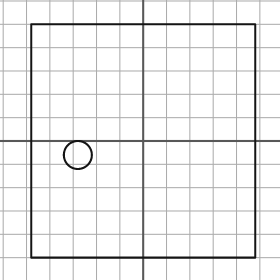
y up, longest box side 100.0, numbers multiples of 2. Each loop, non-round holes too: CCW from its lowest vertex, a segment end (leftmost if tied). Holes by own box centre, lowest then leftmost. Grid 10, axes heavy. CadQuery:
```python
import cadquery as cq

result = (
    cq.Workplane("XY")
    .moveTo(-48.0, -50.0)
    .lineTo(48.0, -50.0)
    .lineTo(48.0, 50.0)
    .lineTo(-48.0, 50.0)
    .close()
    .moveTo(-28.0, -6.0)
    .circle(6.0)
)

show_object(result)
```